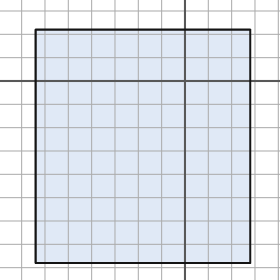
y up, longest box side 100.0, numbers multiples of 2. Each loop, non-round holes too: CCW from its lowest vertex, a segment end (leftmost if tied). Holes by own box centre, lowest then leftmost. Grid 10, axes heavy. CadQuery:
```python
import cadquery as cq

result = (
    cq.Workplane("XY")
    .moveTo(-64.0, -78.0)
    .lineTo(28.0, -78.0)
    .lineTo(28.0, 22.0)
    .lineTo(-64.0, 22.0)
    .close()
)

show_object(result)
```